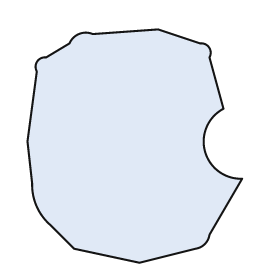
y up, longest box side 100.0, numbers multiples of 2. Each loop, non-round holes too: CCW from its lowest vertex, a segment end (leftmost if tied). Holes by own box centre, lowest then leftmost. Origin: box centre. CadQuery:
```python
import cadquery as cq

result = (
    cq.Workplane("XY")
    .moveTo(2.0, -50.0)
    .lineTo(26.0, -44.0)
    .threePointArc((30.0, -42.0), (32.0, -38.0))
    .lineTo(46.0, -14.0)
    .threePointArc((30.0, -2.0), (38.0, 16.0))
    .lineTo(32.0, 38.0)
    .threePointArc((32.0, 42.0), (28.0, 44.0))
    .lineTo(10.0, 50.0)
    .lineTo(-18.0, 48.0)
    .threePointArc((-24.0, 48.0), (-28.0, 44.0))
    .lineTo(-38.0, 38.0)
    .threePointArc((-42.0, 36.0), (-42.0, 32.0))
    .lineTo(-46.0, 2.0)
    .lineTo(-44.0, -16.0)
    .threePointArc((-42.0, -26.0), (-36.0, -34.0))
    .lineTo(-26.0, -44.0)
    .close()
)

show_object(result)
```